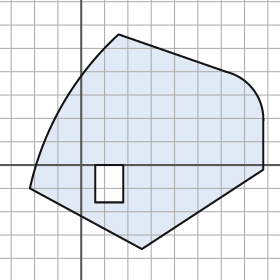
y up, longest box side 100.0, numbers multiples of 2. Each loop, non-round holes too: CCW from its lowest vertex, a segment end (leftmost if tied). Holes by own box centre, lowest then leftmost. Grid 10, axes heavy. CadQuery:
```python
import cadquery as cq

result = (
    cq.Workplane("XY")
    .moveTo(26.0, -36.0)
    .lineTo(78.0, -2.0)
    .lineTo(78.0, 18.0)
    .threePointArc((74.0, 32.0), (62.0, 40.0))
    .lineTo(16.0, 56.0)
    .threePointArc((-8.0, 26.0), (-22.0, -10.0))
    .close()
    .moveTo(6.0, -16.0)
    .lineTo(18.0, -16.0)
    .lineTo(18.0, 0.0)
    .lineTo(6.0, 0.0)
    .close()
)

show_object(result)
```